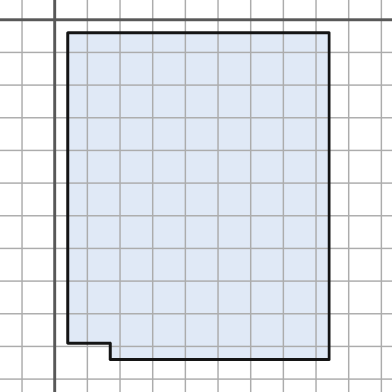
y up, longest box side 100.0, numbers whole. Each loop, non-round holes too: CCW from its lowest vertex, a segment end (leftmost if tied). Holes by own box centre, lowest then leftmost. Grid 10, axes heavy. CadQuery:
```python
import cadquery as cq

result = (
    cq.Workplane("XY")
    .moveTo(17.0, -104.0)
    .lineTo(84.0, -104.0)
    .lineTo(84.0, -4.0)
    .lineTo(4.0, -4.0)
    .lineTo(4.0, -99.0)
    .lineTo(17.0, -99.0)
    .close()
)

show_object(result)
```